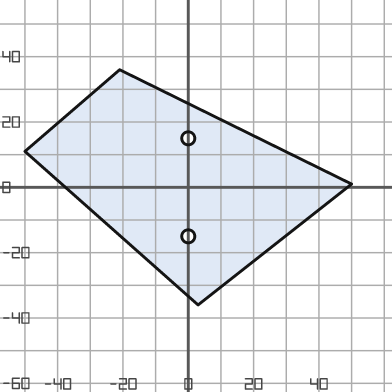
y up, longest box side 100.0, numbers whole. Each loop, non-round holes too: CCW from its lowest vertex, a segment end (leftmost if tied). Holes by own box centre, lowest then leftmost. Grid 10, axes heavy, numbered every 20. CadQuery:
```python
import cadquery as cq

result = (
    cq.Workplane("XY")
    .moveTo(3.0, -36.0)
    .lineTo(50.0, 1.0)
    .lineTo(-21.0, 36.0)
    .lineTo(-50.0, 11.0)
    .close()
    .moveTo(0.0, -15.0)
    .circle(2.0)
    .moveTo(0.0, 15.0)
    .circle(2.0)
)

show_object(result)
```